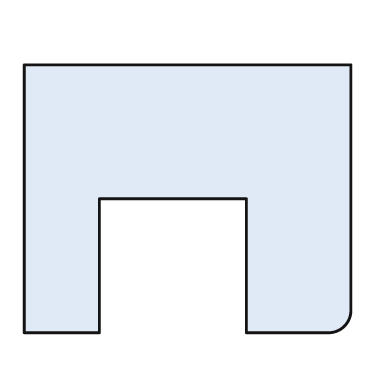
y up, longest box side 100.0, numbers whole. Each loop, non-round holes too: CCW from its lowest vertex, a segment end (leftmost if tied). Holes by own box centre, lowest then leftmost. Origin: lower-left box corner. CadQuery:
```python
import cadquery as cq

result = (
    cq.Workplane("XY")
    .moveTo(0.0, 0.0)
    .lineTo(23.0, 0.0)
    .lineTo(23.0, 41.0)
    .lineTo(68.0, 41.0)
    .lineTo(68.0, 0.0)
    .lineTo(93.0, 0.0)
    .threePointArc((98.0, 2.0), (100.0, 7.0))
    .lineTo(100.0, 82.0)
    .lineTo(0.0, 82.0)
    .close()
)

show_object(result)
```